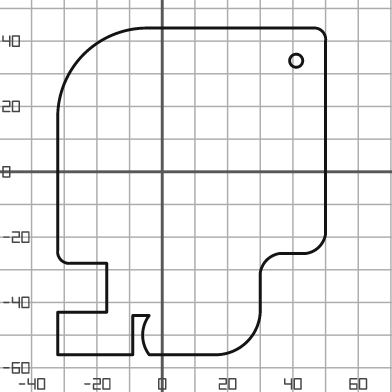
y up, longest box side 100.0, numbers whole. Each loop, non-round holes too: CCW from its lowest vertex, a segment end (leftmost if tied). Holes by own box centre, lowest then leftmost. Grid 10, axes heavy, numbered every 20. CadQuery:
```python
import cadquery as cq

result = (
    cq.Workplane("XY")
    .moveTo(-32.0, -56.0)
    .lineTo(-9.0, -56.0)
    .lineTo(-9.0, -44.0)
    .lineTo(-4.0, -44.0)
    .threePointArc((-6.0, -50.0), (-4.0, -56.0))
    .lineTo(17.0, -56.0)
    .threePointArc((26.0, -52.0), (30.0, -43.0))
    .lineTo(30.0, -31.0)
    .threePointArc((32.0, -27.0), (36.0, -25.0))
    .lineTo(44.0, -25.0)
    .threePointArc((48.0, -23.0), (50.0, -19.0))
    .lineTo(50.0, 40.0)
    .threePointArc((49.0, 43.0), (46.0, 44.0))
    .lineTo(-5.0, 44.0)
    .threePointArc((-24.0, 36.0), (-32.0, 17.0))
    .lineTo(-32.0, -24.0)
    .threePointArc((-31.0, -27.0), (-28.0, -28.0))
    .lineTo(-17.0, -28.0)
    .lineTo(-17.0, -43.0)
    .lineTo(-32.0, -43.0)
    .close()
    .moveTo(41.0, 34.0)
    .circle(2.0)
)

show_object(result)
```